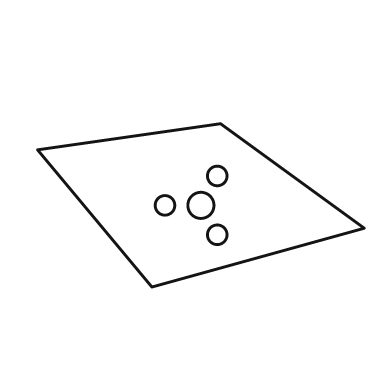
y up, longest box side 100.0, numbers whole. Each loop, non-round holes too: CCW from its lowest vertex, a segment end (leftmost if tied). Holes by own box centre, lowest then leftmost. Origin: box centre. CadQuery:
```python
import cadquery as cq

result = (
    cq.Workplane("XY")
    .moveTo(-15.0, -25.0)
    .lineTo(50.0, -7.0)
    .lineTo(6.0, 25.0)
    .lineTo(-50.0, 17.0)
    .close()
    .moveTo(5.0, -9.0)
    .circle(3.0)
    .moveTo(-11.0, 0.0)
    .circle(3.0)
    .moveTo(0.0, 0.0)
    .circle(4.0)
    .moveTo(5.0, 9.0)
    .circle(3.0)
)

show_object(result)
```